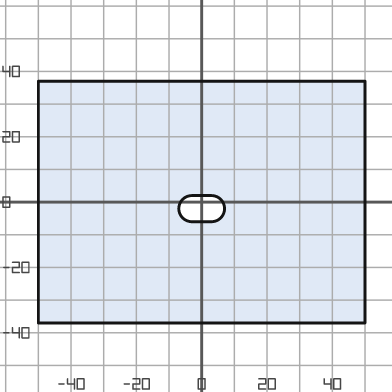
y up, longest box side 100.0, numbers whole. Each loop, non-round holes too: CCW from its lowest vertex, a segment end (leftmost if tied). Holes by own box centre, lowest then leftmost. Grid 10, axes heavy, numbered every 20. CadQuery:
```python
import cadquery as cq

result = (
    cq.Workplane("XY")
    .moveTo(-50.0, -37.0)
    .lineTo(50.0, -37.0)
    .lineTo(50.0, 37.0)
    .lineTo(-50.0, 37.0)
    .close()
    .moveTo(-3.0, -6.0)
    .lineTo(3.0, -6.0)
    .threePointArc((7.0, -2.0), (3.0, 2.0))
    .lineTo(-3.0, 2.0)
    .threePointArc((-7.0, -2.0), (-3.0, -6.0))
    .close()
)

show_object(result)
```